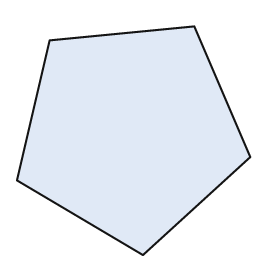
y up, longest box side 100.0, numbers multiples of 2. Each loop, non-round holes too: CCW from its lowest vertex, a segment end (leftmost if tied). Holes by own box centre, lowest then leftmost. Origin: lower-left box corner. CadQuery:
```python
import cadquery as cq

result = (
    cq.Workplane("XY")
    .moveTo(54.0, 0.0)
    .lineTo(100.0, 42.0)
    .lineTo(76.0, 98.0)
    .lineTo(14.0, 92.0)
    .lineTo(0.0, 32.0)
    .close()
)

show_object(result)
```